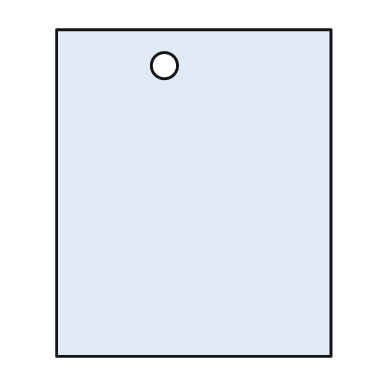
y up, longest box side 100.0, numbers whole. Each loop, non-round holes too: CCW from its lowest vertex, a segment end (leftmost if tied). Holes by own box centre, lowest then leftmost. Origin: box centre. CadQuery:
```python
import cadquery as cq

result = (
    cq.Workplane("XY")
    .moveTo(-42.0, -50.0)
    .lineTo(42.0, -50.0)
    .lineTo(42.0, 50.0)
    .lineTo(-42.0, 50.0)
    .close()
    .moveTo(-9.0, 39.0)
    .circle(4.0)
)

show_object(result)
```